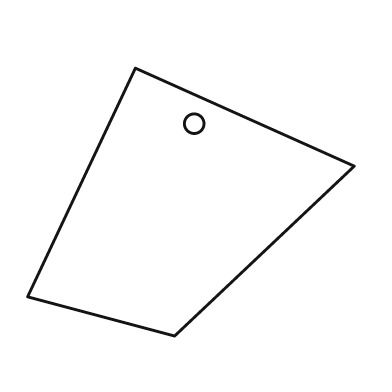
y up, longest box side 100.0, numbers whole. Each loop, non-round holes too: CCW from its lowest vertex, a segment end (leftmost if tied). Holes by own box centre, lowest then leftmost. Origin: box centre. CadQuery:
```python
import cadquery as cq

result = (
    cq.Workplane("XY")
    .moveTo(-5.0, -41.0)
    .lineTo(50.0, 11.0)
    .lineTo(-17.0, 41.0)
    .lineTo(-50.0, -29.0)
    .close()
    .moveTo(1.0, 24.0)
    .circle(3.0)
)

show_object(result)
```